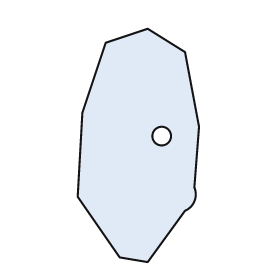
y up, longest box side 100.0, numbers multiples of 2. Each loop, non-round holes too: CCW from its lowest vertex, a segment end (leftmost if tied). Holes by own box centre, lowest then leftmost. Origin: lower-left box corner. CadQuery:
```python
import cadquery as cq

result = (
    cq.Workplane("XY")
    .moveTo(30.0, 0.0)
    .lineTo(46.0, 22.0)
    .threePointArc((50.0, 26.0), (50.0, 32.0))
    .lineTo(52.0, 58.0)
    .lineTo(46.0, 90.0)
    .lineTo(30.0, 100.0)
    .lineTo(12.0, 94.0)
    .lineTo(2.0, 64.0)
    .lineTo(0.0, 28.0)
    .lineTo(18.0, 2.0)
    .close()
    .moveTo(36.0, 54.0)
    .circle(4.0)
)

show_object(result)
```